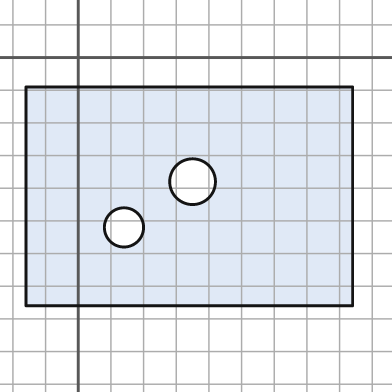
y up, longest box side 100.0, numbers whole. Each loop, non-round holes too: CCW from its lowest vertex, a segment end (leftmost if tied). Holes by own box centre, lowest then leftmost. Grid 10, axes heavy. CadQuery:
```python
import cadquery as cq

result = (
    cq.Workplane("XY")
    .moveTo(-16.0, -76.0)
    .lineTo(84.0, -76.0)
    .lineTo(84.0, -9.0)
    .lineTo(-16.0, -9.0)
    .close()
    .moveTo(14.0, -52.0)
    .circle(6.0)
    .moveTo(35.0, -38.0)
    .circle(7.0)
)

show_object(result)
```